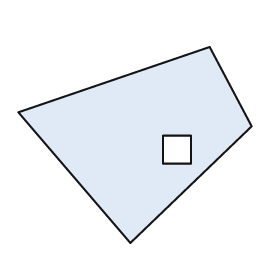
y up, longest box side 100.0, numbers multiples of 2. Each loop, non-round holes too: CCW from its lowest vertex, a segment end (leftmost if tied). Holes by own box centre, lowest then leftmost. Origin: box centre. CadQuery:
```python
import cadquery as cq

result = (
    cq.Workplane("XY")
    .moveTo(-2.0, -42.0)
    .lineTo(50.0, 8.0)
    .lineTo(32.0, 42.0)
    .lineTo(-50.0, 14.0)
    .close()
    .moveTo(12.0, -8.0)
    .lineTo(24.0, -8.0)
    .lineTo(24.0, 4.0)
    .lineTo(12.0, 4.0)
    .close()
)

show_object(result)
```